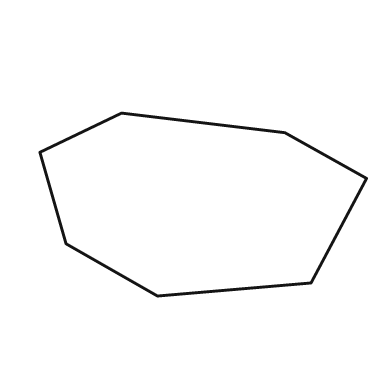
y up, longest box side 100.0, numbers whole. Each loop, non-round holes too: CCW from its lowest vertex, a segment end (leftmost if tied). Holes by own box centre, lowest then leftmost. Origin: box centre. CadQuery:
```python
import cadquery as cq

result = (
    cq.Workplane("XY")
    .moveTo(-14.0, -28.0)
    .lineTo(33.0, -24.0)
    .lineTo(50.0, 8.0)
    .lineTo(25.0, 22.0)
    .lineTo(-25.0, 28.0)
    .lineTo(-50.0, 16.0)
    .lineTo(-42.0, -12.0)
    .close()
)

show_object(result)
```